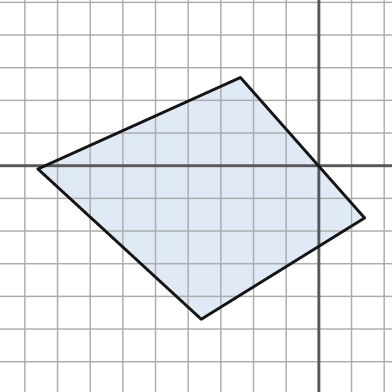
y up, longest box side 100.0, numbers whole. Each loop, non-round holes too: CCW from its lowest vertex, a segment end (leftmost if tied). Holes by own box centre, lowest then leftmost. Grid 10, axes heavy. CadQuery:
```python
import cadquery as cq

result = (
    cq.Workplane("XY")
    .moveTo(-36.0, -47.0)
    .lineTo(14.0, -16.0)
    .lineTo(-24.0, 27.0)
    .lineTo(-86.0, -1.0)
    .close()
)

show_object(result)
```